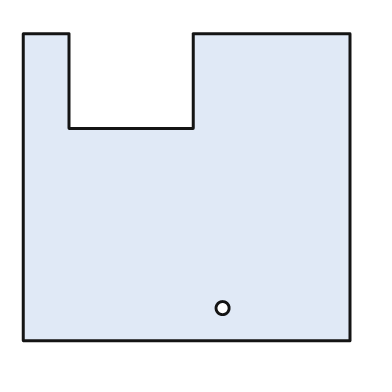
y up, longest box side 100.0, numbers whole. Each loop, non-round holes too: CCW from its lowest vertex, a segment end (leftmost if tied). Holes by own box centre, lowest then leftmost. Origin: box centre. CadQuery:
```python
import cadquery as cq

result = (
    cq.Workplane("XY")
    .moveTo(-50.0, -47.0)
    .lineTo(50.0, -47.0)
    .lineTo(50.0, 47.0)
    .lineTo(2.0, 47.0)
    .lineTo(2.0, 18.0)
    .lineTo(-36.0, 18.0)
    .lineTo(-36.0, 47.0)
    .lineTo(-50.0, 47.0)
    .close()
    .moveTo(11.0, -37.0)
    .circle(2.0)
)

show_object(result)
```